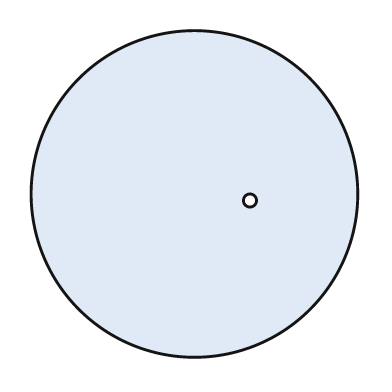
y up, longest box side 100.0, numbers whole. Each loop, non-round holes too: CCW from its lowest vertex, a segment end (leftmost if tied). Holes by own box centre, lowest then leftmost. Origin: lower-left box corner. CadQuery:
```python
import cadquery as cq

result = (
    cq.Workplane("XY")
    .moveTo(50.0, 50.0)
    .circle(50.0)
    .moveTo(67.0, 48.0)
    .circle(2.0)
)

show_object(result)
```